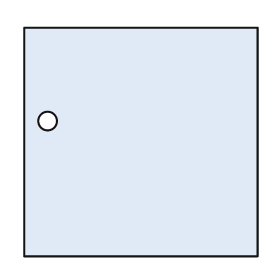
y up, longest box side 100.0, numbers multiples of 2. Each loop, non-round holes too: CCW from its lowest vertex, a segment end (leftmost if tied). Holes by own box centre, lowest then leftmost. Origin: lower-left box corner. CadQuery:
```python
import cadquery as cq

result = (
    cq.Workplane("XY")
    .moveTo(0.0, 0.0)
    .lineTo(100.0, 0.0)
    .lineTo(100.0, 98.0)
    .lineTo(0.0, 98.0)
    .close()
    .moveTo(10.0, 58.0)
    .circle(4.0)
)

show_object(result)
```